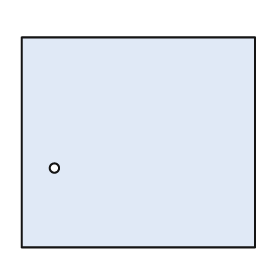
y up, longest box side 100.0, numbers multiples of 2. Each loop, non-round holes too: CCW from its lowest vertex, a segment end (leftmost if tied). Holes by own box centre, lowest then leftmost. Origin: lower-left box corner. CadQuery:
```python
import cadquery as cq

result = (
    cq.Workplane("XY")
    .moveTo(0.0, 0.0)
    .lineTo(100.0, 0.0)
    .lineTo(100.0, 90.0)
    .lineTo(0.0, 90.0)
    .close()
    .moveTo(14.0, 34.0)
    .circle(2.0)
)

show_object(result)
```